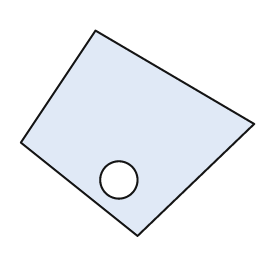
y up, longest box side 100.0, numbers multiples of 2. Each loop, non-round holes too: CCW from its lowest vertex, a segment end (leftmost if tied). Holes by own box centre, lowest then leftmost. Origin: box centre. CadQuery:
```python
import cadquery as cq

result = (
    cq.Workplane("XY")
    .moveTo(0.0, -44.0)
    .lineTo(50.0, 4.0)
    .lineTo(-18.0, 44.0)
    .lineTo(-50.0, -4.0)
    .close()
    .moveTo(-8.0, -20.0)
    .circle(8.0)
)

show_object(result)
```